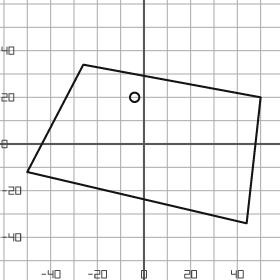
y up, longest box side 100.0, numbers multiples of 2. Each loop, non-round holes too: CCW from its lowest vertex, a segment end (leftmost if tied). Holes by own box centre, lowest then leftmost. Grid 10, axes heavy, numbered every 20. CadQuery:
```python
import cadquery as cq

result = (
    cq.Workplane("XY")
    .moveTo(44.0, -34.0)
    .lineTo(50.0, 20.0)
    .lineTo(-26.0, 34.0)
    .lineTo(-50.0, -12.0)
    .close()
    .moveTo(-4.0, 20.0)
    .circle(2.0)
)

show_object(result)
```